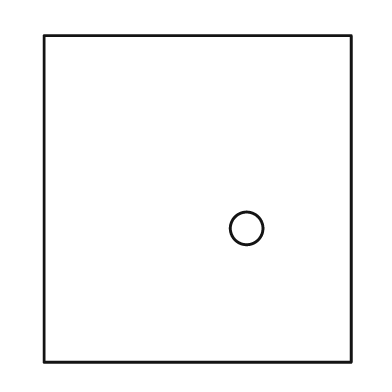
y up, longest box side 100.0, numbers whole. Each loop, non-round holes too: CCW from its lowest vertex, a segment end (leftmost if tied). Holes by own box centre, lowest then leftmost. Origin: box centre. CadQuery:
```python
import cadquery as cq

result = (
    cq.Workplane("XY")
    .moveTo(-47.0, -50.0)
    .lineTo(47.0, -50.0)
    .lineTo(47.0, 50.0)
    .lineTo(-47.0, 50.0)
    .close()
    .moveTo(15.0, -9.0)
    .circle(5.0)
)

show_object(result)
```